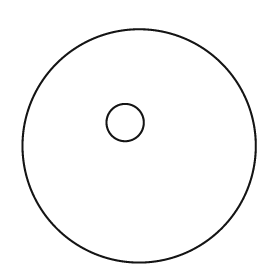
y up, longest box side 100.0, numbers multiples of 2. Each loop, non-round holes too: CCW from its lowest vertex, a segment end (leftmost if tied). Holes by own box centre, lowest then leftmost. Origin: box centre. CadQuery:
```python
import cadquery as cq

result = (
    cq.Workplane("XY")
    .moveTo(0.0, 0.0)
    .circle(50.0)
    .moveTo(-6.0, 10.0)
    .circle(8.0)
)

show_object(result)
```